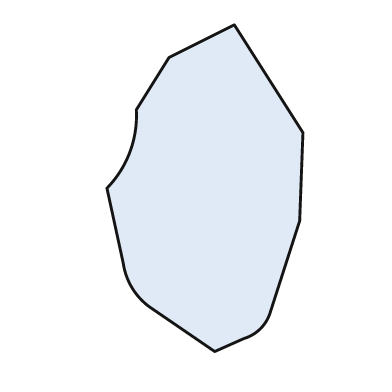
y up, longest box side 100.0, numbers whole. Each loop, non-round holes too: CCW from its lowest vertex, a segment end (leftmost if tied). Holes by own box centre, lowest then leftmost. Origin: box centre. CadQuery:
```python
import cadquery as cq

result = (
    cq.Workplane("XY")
    .moveTo(3.0, -50.0)
    .lineTo(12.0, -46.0)
    .threePointArc((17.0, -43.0), (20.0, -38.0))
    .lineTo(29.0, -10.0)
    .lineTo(30.0, 17.0)
    .lineTo(9.0, 50.0)
    .lineTo(-11.0, 40.0)
    .lineTo(-21.0, 24.0)
    .threePointArc((-23.0, 11.0), (-30.0, 0.0))
    .lineTo(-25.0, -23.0)
    .threePointArc((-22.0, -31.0), (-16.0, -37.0))
    .close()
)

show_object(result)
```